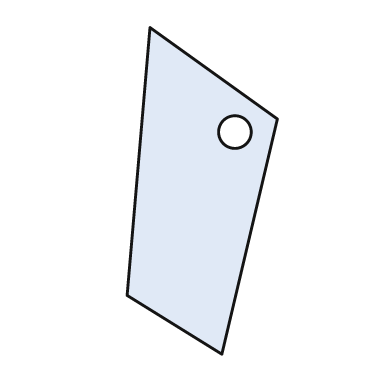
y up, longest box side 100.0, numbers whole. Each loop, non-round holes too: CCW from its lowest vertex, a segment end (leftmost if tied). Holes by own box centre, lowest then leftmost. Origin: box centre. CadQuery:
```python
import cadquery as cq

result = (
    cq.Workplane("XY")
    .moveTo(6.0, -50.0)
    .lineTo(23.0, 22.0)
    .lineTo(-16.0, 50.0)
    .lineTo(-23.0, -32.0)
    .close()
    .moveTo(10.0, 18.0)
    .circle(5.0)
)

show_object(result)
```